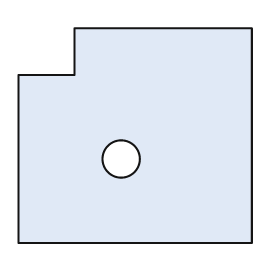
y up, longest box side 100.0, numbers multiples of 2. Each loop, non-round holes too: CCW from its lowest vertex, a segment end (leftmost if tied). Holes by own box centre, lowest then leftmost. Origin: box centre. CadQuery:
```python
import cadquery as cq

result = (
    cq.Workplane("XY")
    .moveTo(-50.0, -46.0)
    .lineTo(50.0, -46.0)
    .lineTo(50.0, 46.0)
    .lineTo(-26.0, 46.0)
    .lineTo(-26.0, 26.0)
    .lineTo(-50.0, 26.0)
    .close()
    .moveTo(-6.0, -10.0)
    .circle(8.0)
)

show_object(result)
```